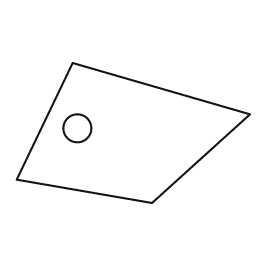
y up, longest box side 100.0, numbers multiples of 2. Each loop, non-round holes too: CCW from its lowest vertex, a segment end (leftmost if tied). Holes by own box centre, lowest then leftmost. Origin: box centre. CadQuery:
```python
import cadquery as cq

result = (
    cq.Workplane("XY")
    .moveTo(8.0, -30.0)
    .lineTo(50.0, 8.0)
    .lineTo(-26.0, 30.0)
    .lineTo(-50.0, -20.0)
    .close()
    .moveTo(-24.0, 2.0)
    .circle(6.0)
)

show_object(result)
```